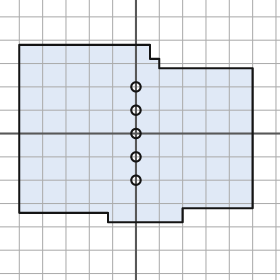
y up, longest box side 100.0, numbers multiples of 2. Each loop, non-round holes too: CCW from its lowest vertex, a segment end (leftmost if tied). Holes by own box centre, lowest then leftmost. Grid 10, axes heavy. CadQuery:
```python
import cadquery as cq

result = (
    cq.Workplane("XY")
    .moveTo(-12.0, -38.0)
    .lineTo(20.0, -38.0)
    .lineTo(20.0, -32.0)
    .lineTo(50.0, -32.0)
    .lineTo(50.0, 28.0)
    .lineTo(10.0, 28.0)
    .lineTo(10.0, 32.0)
    .lineTo(6.0, 32.0)
    .lineTo(6.0, 38.0)
    .lineTo(-50.0, 38.0)
    .lineTo(-50.0, -34.0)
    .lineTo(-12.0, -34.0)
    .close()
    .moveTo(0.0, -20.0)
    .circle(2.0)
    .moveTo(0.0, -10.0)
    .circle(2.0)
    .moveTo(0.0, 0.0)
    .circle(2.0)
    .moveTo(0.0, 10.0)
    .circle(2.0)
    .moveTo(0.0, 20.0)
    .circle(2.0)
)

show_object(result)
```